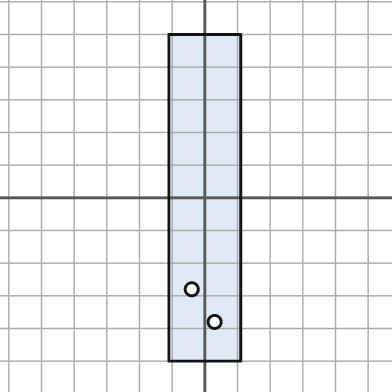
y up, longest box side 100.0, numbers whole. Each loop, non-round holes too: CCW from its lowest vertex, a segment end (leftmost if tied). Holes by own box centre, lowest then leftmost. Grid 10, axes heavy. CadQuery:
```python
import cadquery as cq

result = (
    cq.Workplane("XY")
    .moveTo(-11.0, -50.0)
    .lineTo(11.0, -50.0)
    .lineTo(11.0, 50.0)
    .lineTo(-11.0, 50.0)
    .close()
    .moveTo(3.0, -38.0)
    .circle(2.0)
    .moveTo(-4.0, -28.0)
    .circle(2.0)
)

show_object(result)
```